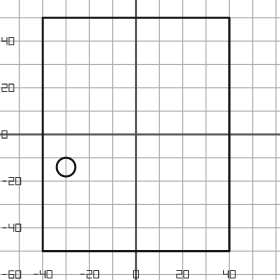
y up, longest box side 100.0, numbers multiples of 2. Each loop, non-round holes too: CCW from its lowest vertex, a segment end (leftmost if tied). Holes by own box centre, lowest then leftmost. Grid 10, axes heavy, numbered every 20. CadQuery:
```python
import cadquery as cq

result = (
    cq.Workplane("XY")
    .moveTo(-40.0, -50.0)
    .lineTo(40.0, -50.0)
    .lineTo(40.0, 50.0)
    .lineTo(-40.0, 50.0)
    .close()
    .moveTo(-30.0, -14.0)
    .circle(4.0)
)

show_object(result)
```